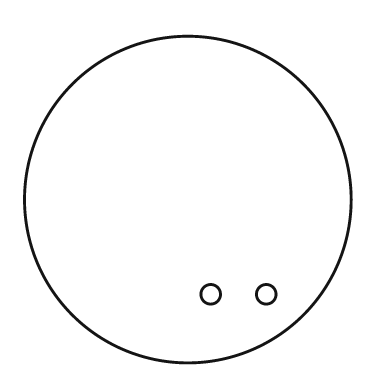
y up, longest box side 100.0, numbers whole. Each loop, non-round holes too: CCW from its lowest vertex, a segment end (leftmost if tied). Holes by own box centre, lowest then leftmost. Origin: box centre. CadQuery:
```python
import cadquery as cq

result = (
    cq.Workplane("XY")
    .moveTo(0.0, 0.0)
    .circle(50.0)
    .moveTo(7.0, -29.0)
    .circle(3.0)
    .moveTo(24.0, -29.0)
    .circle(3.0)
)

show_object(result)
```